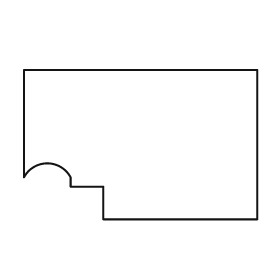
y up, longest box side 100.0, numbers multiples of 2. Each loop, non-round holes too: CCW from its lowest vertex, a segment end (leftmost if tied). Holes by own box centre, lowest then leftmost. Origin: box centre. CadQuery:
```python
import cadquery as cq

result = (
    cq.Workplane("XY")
    .moveTo(-16.0, -32.0)
    .lineTo(50.0, -32.0)
    .lineTo(50.0, 32.0)
    .lineTo(-50.0, 32.0)
    .lineTo(-50.0, -14.0)
    .threePointArc((-40.0, -8.0), (-30.0, -14.0))
    .lineTo(-30.0, -18.0)
    .lineTo(-16.0, -18.0)
    .close()
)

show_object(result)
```